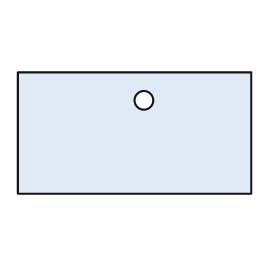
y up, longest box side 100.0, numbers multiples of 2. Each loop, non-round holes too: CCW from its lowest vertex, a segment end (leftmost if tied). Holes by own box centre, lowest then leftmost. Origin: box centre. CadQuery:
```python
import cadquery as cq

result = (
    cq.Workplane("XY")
    .moveTo(-50.0, -26.0)
    .lineTo(50.0, -26.0)
    .lineTo(50.0, 26.0)
    .lineTo(-50.0, 26.0)
    .close()
    .moveTo(4.0, 14.0)
    .circle(4.0)
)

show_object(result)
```